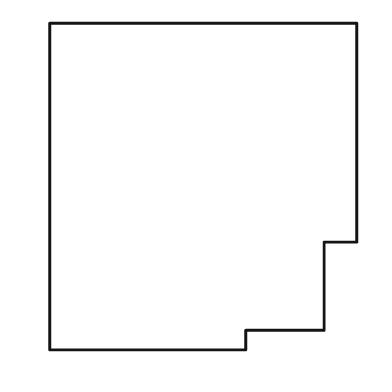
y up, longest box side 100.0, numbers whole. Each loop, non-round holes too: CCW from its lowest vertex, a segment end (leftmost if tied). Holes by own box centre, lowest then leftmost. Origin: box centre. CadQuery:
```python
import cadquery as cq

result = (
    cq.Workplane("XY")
    .moveTo(-47.0, -50.0)
    .lineTo(13.0, -50.0)
    .lineTo(13.0, -44.0)
    .lineTo(37.0, -44.0)
    .lineTo(37.0, -17.0)
    .lineTo(47.0, -17.0)
    .lineTo(47.0, 50.0)
    .lineTo(-47.0, 50.0)
    .close()
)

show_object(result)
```